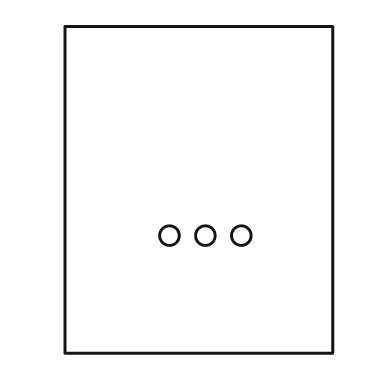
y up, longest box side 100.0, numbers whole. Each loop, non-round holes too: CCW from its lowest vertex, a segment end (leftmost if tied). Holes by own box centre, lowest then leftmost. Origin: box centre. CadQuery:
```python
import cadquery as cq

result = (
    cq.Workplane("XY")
    .moveTo(-41.0, -50.0)
    .lineTo(41.0, -50.0)
    .lineTo(41.0, 50.0)
    .lineTo(-41.0, 50.0)
    .close()
    .moveTo(-9.0, -14.0)
    .circle(3.0)
    .moveTo(2.0, -14.0)
    .circle(3.0)
    .moveTo(13.0, -14.0)
    .circle(3.0)
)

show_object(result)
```